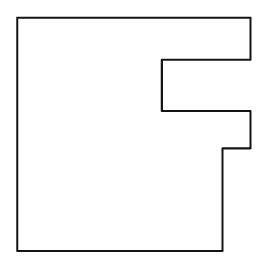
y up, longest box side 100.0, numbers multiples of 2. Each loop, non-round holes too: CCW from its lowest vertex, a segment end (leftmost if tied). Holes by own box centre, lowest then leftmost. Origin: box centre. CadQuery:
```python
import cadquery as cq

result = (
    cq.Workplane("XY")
    .moveTo(-50.0, -50.0)
    .lineTo(38.0, -50.0)
    .lineTo(38.0, -6.0)
    .lineTo(50.0, -6.0)
    .lineTo(50.0, 10.0)
    .lineTo(12.0, 10.0)
    .lineTo(12.0, 32.0)
    .lineTo(50.0, 32.0)
    .lineTo(50.0, 50.0)
    .lineTo(-50.0, 50.0)
    .close()
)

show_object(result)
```